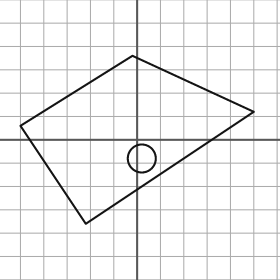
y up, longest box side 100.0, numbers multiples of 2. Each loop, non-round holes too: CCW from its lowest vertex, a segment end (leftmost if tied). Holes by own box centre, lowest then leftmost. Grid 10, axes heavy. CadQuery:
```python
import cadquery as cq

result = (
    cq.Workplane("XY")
    .moveTo(-22.0, -36.0)
    .lineTo(50.0, 12.0)
    .lineTo(-2.0, 36.0)
    .lineTo(-50.0, 6.0)
    .close()
    .moveTo(2.0, -8.0)
    .circle(6.0)
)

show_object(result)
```